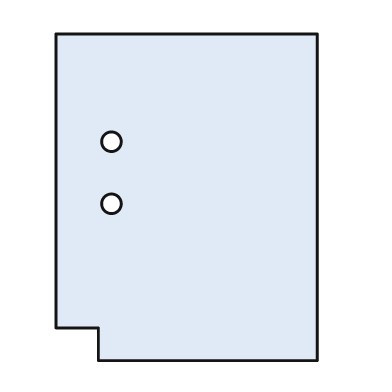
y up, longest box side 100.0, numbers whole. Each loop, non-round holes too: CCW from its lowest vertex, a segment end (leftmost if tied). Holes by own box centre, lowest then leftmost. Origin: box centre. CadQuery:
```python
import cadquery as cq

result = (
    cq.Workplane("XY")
    .moveTo(-27.0, -50.0)
    .lineTo(40.0, -50.0)
    .lineTo(40.0, 50.0)
    .lineTo(-40.0, 50.0)
    .lineTo(-40.0, -40.0)
    .lineTo(-27.0, -40.0)
    .close()
    .moveTo(-23.0, -2.0)
    .circle(3.0)
    .moveTo(-23.0, 17.0)
    .circle(3.0)
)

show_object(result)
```